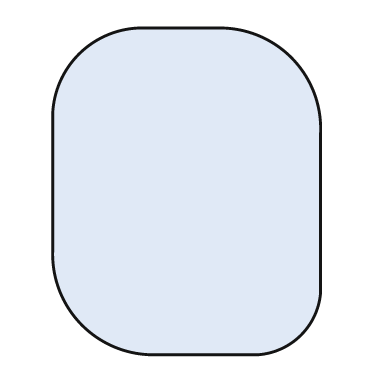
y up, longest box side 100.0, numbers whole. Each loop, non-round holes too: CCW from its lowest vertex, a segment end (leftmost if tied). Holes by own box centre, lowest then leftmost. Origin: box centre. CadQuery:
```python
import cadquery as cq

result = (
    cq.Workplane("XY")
    .moveTo(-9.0, -50.0)
    .lineTo(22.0, -50.0)
    .threePointArc((35.0, -44.0), (41.0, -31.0))
    .lineTo(41.0, 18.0)
    .threePointArc((32.0, 41.0), (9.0, 50.0))
    .lineTo(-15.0, 50.0)
    .threePointArc((-33.0, 42.0), (-41.0, 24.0))
    .lineTo(-41.0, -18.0)
    .threePointArc((-32.0, -41.0), (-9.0, -50.0))
    .close()
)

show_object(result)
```